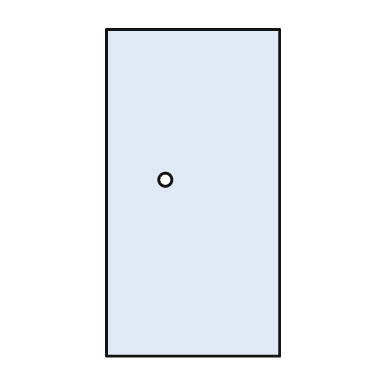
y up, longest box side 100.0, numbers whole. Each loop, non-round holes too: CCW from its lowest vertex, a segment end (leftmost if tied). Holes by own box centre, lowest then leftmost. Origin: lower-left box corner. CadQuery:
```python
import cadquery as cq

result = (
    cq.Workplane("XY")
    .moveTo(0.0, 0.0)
    .lineTo(53.0, 0.0)
    .lineTo(53.0, 100.0)
    .lineTo(0.0, 100.0)
    .close()
    .moveTo(18.0, 54.0)
    .circle(2.0)
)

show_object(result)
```